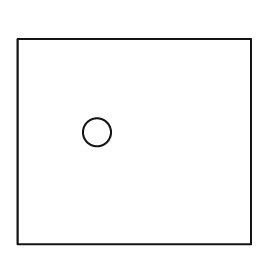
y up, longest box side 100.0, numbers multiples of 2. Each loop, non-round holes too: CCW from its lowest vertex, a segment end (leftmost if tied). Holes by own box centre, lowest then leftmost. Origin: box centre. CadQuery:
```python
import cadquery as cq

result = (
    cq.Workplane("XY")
    .moveTo(-50.0, -44.0)
    .lineTo(50.0, -44.0)
    .lineTo(50.0, 44.0)
    .lineTo(-50.0, 44.0)
    .close()
    .moveTo(-16.0, 4.0)
    .circle(6.0)
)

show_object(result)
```